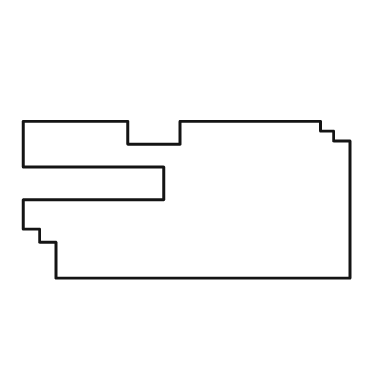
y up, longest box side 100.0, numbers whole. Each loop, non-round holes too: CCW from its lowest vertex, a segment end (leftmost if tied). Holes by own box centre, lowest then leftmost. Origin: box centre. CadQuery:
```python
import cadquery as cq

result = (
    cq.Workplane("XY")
    .moveTo(-40.0, -24.0)
    .lineTo(50.0, -24.0)
    .lineTo(50.0, 18.0)
    .lineTo(45.0, 18.0)
    .lineTo(45.0, 21.0)
    .lineTo(41.0, 21.0)
    .lineTo(41.0, 24.0)
    .lineTo(-2.0, 24.0)
    .lineTo(-2.0, 17.0)
    .lineTo(-18.0, 17.0)
    .lineTo(-18.0, 24.0)
    .lineTo(-50.0, 24.0)
    .lineTo(-50.0, 10.0)
    .lineTo(-7.0, 10.0)
    .lineTo(-7.0, 0.0)
    .lineTo(-50.0, 0.0)
    .lineTo(-50.0, -9.0)
    .lineTo(-45.0, -9.0)
    .lineTo(-45.0, -13.0)
    .lineTo(-40.0, -13.0)
    .close()
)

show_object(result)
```